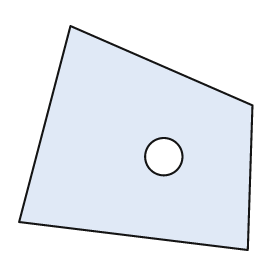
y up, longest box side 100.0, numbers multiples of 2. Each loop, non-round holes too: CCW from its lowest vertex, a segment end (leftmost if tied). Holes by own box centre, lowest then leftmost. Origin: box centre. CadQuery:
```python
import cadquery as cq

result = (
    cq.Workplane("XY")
    .moveTo(48.0, -48.0)
    .lineTo(50.0, 14.0)
    .lineTo(-28.0, 48.0)
    .lineTo(-50.0, -36.0)
    .close()
    .moveTo(12.0, -8.0)
    .circle(8.0)
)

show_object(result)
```